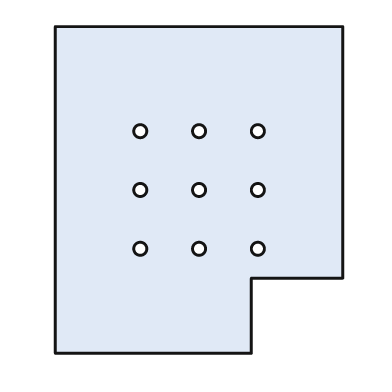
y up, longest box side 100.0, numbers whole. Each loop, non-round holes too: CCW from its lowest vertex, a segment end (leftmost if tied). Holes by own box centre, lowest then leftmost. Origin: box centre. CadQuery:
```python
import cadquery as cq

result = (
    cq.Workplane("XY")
    .moveTo(-44.0, -50.0)
    .lineTo(16.0, -50.0)
    .lineTo(16.0, -27.0)
    .lineTo(44.0, -27.0)
    .lineTo(44.0, 50.0)
    .lineTo(-44.0, 50.0)
    .close()
    .moveTo(-18.0, -18.0)
    .circle(2.0)
    .moveTo(0.0, -18.0)
    .circle(2.0)
    .moveTo(18.0, -18.0)
    .circle(2.0)
    .moveTo(-18.0, 0.0)
    .circle(2.0)
    .moveTo(0.0, 0.0)
    .circle(2.0)
    .moveTo(18.0, 0.0)
    .circle(2.0)
    .moveTo(-18.0, 18.0)
    .circle(2.0)
    .moveTo(0.0, 18.0)
    .circle(2.0)
    .moveTo(18.0, 18.0)
    .circle(2.0)
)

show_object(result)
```